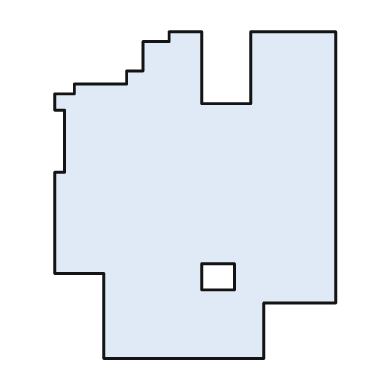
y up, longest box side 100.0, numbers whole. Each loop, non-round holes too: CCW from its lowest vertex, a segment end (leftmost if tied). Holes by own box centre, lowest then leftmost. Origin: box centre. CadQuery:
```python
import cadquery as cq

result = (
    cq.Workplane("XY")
    .moveTo(-28.0, -50.0)
    .lineTo(21.0, -50.0)
    .lineTo(21.0, -33.0)
    .lineTo(43.0, -33.0)
    .lineTo(43.0, 50.0)
    .lineTo(17.0, 50.0)
    .lineTo(17.0, 28.0)
    .lineTo(2.0, 28.0)
    .lineTo(2.0, 50.0)
    .lineTo(-8.0, 50.0)
    .lineTo(-8.0, 47.0)
    .lineTo(-16.0, 47.0)
    .lineTo(-16.0, 38.0)
    .lineTo(-21.0, 38.0)
    .lineTo(-21.0, 34.0)
    .lineTo(-37.0, 34.0)
    .lineTo(-37.0, 31.0)
    .lineTo(-43.0, 31.0)
    .lineTo(-43.0, 26.0)
    .lineTo(-40.0, 26.0)
    .lineTo(-40.0, 7.0)
    .lineTo(-43.0, 7.0)
    .lineTo(-43.0, -24.0)
    .lineTo(-28.0, -24.0)
    .close()
    .moveTo(2.0, -29.0)
    .lineTo(12.0, -29.0)
    .lineTo(12.0, -21.0)
    .lineTo(2.0, -21.0)
    .close()
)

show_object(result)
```